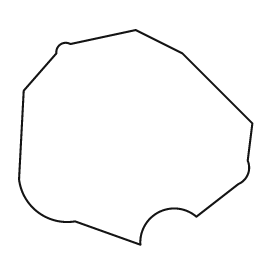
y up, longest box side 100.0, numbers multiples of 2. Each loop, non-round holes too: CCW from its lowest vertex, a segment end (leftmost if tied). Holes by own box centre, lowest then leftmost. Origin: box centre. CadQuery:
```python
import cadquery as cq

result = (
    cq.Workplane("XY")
    .moveTo(2.0, -46.0)
    .threePointArc((10.0, -32.0), (26.0, -34.0))
    .lineTo(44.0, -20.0)
    .threePointArc((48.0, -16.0), (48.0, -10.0))
    .lineTo(50.0, 6.0)
    .lineTo(20.0, 36.0)
    .lineTo(0.0, 46.0)
    .lineTo(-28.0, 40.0)
    .threePointArc((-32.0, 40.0), (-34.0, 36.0))
    .lineTo(-48.0, 20.0)
    .lineTo(-50.0, -18.0)
    .threePointArc((-42.0, -32.0), (-26.0, -36.0))
    .close()
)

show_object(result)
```